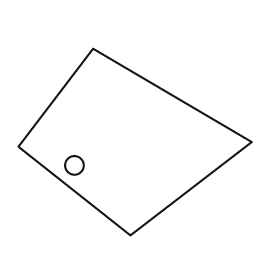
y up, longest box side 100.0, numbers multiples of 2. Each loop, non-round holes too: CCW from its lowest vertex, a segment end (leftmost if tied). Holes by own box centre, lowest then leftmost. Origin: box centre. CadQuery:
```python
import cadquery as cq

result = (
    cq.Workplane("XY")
    .moveTo(-2.0, -40.0)
    .lineTo(50.0, 0.0)
    .lineTo(-18.0, 40.0)
    .lineTo(-50.0, -2.0)
    .close()
    .moveTo(-26.0, -10.0)
    .circle(4.0)
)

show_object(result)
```